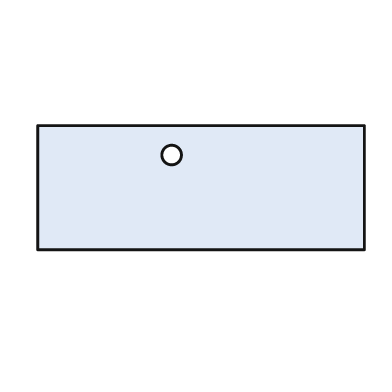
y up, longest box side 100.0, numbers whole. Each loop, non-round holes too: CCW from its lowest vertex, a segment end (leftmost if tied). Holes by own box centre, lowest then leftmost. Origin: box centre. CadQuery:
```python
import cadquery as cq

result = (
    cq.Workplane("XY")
    .moveTo(-50.0, -19.0)
    .lineTo(50.0, -19.0)
    .lineTo(50.0, 19.0)
    .lineTo(-50.0, 19.0)
    .close()
    .moveTo(-9.0, 10.0)
    .circle(3.0)
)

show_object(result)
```